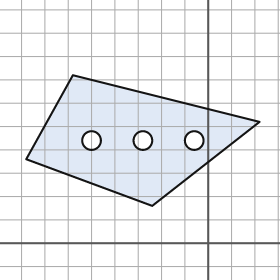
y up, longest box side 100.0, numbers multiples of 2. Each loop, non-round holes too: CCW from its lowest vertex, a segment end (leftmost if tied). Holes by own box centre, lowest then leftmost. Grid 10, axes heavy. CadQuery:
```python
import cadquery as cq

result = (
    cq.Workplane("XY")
    .moveTo(-24.0, 16.0)
    .lineTo(22.0, 52.0)
    .lineTo(-58.0, 72.0)
    .lineTo(-78.0, 36.0)
    .close()
    .moveTo(-50.0, 44.0)
    .circle(4.0)
    .moveTo(-28.0, 44.0)
    .circle(4.0)
    .moveTo(-6.0, 44.0)
    .circle(4.0)
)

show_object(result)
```